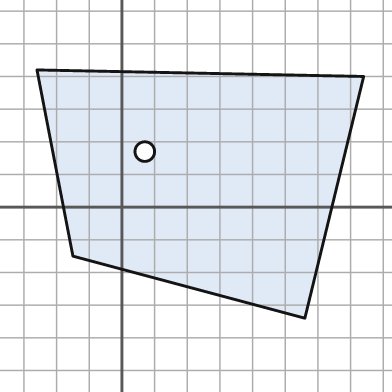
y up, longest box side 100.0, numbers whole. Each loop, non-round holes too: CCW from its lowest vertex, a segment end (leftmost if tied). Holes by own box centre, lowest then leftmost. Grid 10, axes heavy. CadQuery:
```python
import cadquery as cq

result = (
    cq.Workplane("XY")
    .moveTo(56.0, -34.0)
    .lineTo(74.0, 40.0)
    .lineTo(-26.0, 42.0)
    .lineTo(-15.0, -15.0)
    .close()
    .moveTo(7.0, 17.0)
    .circle(3.0)
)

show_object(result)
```